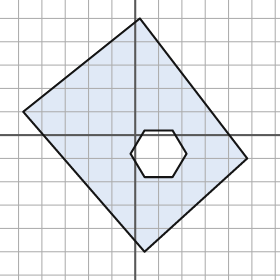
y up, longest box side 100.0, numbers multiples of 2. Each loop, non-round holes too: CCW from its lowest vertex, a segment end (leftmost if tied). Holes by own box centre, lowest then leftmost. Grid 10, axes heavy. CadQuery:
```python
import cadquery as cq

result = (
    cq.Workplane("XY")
    .moveTo(4.0, -50.0)
    .lineTo(48.0, -10.0)
    .lineTo(2.0, 50.0)
    .lineTo(-48.0, 10.0)
    .close()
    .moveTo(4.0, -18.0)
    .lineTo(16.0, -18.0)
    .lineTo(22.0, -8.0)
    .lineTo(16.0, 2.0)
    .lineTo(4.0, 2.0)
    .lineTo(-2.0, -8.0)
    .close()
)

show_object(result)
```